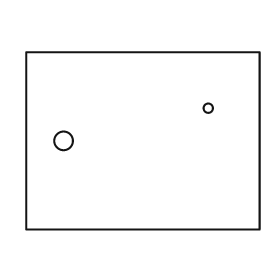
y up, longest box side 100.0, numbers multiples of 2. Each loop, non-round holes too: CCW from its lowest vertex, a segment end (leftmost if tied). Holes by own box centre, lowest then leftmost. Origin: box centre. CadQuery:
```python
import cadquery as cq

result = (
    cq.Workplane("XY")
    .moveTo(-50.0, -38.0)
    .lineTo(50.0, -38.0)
    .lineTo(50.0, 38.0)
    .lineTo(-50.0, 38.0)
    .close()
    .moveTo(-34.0, 0.0)
    .circle(4.0)
    .moveTo(28.0, 14.0)
    .circle(2.0)
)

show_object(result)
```